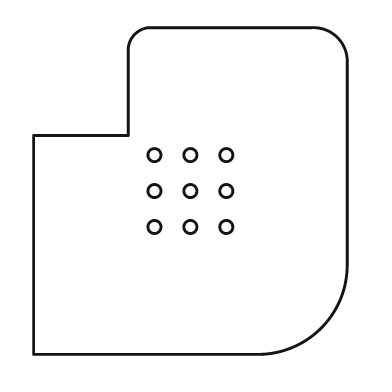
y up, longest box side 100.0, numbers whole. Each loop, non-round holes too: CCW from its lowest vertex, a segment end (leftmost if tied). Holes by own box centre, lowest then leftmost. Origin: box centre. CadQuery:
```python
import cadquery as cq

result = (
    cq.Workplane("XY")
    .moveTo(-48.0, -50.0)
    .lineTo(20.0, -50.0)
    .threePointArc((40.0, -42.0), (48.0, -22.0))
    .lineTo(48.0, 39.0)
    .threePointArc((45.0, 47.0), (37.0, 50.0))
    .lineTo(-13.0, 50.0)
    .threePointArc((-17.0, 48.0), (-19.0, 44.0))
    .lineTo(-19.0, 17.0)
    .lineTo(-48.0, 17.0)
    .close()
    .moveTo(-11.0, -11.0)
    .circle(2.0)
    .moveTo(0.0, -11.0)
    .circle(2.0)
    .moveTo(11.0, -11.0)
    .circle(2.0)
    .moveTo(-11.0, 0.0)
    .circle(2.0)
    .moveTo(0.0, 0.0)
    .circle(2.0)
    .moveTo(11.0, 0.0)
    .circle(2.0)
    .moveTo(-11.0, 11.0)
    .circle(2.0)
    .moveTo(0.0, 11.0)
    .circle(2.0)
    .moveTo(11.0, 11.0)
    .circle(2.0)
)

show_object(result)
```